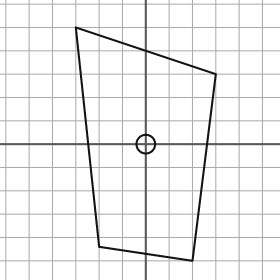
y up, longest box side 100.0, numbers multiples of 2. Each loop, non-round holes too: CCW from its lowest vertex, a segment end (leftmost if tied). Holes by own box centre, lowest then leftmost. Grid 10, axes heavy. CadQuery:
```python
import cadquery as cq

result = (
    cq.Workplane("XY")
    .moveTo(20.0, -50.0)
    .lineTo(30.0, 30.0)
    .lineTo(-30.0, 50.0)
    .lineTo(-20.0, -44.0)
    .close()
    .moveTo(0.0, 0.0)
    .circle(4.0)
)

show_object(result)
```